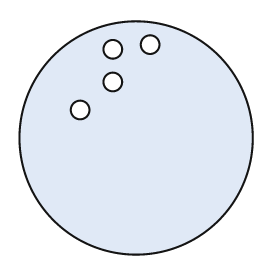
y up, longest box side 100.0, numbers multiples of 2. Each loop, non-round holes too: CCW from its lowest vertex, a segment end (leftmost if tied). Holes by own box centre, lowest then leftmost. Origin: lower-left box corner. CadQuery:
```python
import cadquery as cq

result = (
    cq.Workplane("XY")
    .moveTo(50.0, 50.0)
    .circle(50.0)
    .moveTo(26.0, 62.0)
    .circle(4.0)
    .moveTo(40.0, 74.0)
    .circle(4.0)
    .moveTo(40.0, 88.0)
    .circle(4.0)
    .moveTo(56.0, 90.0)
    .circle(4.0)
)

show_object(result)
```